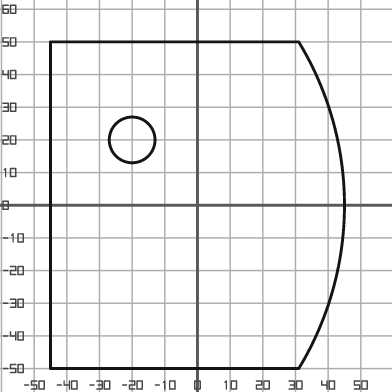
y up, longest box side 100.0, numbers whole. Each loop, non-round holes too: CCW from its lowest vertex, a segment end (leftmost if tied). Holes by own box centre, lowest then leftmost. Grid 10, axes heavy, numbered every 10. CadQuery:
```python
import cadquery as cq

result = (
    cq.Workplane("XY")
    .moveTo(-45.0, -50.0)
    .lineTo(31.0, -50.0)
    .threePointArc((45.0, 0.0), (31.0, 50.0))
    .lineTo(-45.0, 50.0)
    .close()
    .moveTo(-20.0, 20.0)
    .circle(7.0)
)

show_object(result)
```